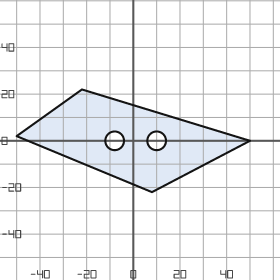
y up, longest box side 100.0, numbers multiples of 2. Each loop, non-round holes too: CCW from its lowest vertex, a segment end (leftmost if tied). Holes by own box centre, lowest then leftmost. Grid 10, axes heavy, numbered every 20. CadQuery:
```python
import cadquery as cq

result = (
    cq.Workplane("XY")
    .moveTo(8.0, -22.0)
    .lineTo(50.0, 0.0)
    .lineTo(-22.0, 22.0)
    .lineTo(-50.0, 2.0)
    .close()
    .moveTo(-8.0, 0.0)
    .circle(4.0)
    .moveTo(10.0, 0.0)
    .circle(4.0)
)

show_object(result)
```